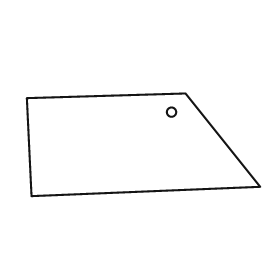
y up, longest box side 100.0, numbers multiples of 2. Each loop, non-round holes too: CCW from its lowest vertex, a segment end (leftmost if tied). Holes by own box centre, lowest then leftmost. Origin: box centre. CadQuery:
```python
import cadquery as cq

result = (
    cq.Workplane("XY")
    .moveTo(-48.0, -22.0)
    .lineTo(50.0, -18.0)
    .lineTo(18.0, 22.0)
    .lineTo(-50.0, 20.0)
    .close()
    .moveTo(12.0, 14.0)
    .circle(2.0)
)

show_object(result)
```